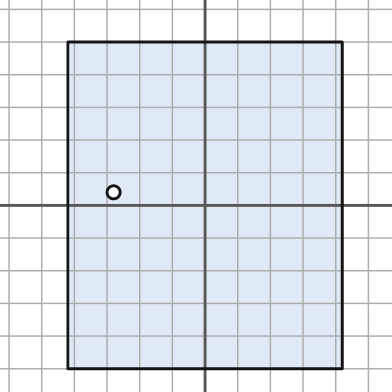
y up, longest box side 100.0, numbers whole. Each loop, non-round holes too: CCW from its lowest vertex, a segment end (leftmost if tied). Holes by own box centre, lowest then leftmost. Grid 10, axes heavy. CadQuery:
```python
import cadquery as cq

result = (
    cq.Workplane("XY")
    .moveTo(-42.0, -50.0)
    .lineTo(42.0, -50.0)
    .lineTo(42.0, 50.0)
    .lineTo(-42.0, 50.0)
    .close()
    .moveTo(-28.0, 4.0)
    .circle(2.0)
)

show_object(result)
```